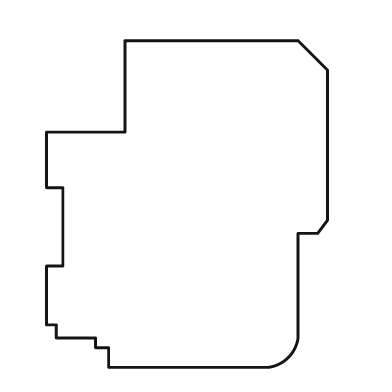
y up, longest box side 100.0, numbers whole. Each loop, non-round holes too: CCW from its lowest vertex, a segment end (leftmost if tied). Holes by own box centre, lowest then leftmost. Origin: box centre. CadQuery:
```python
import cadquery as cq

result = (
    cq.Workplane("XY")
    .moveTo(-24.0, -50.0)
    .lineTo(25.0, -50.0)
    .threePointArc((31.0, -47.0), (34.0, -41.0))
    .lineTo(34.0, -9.0)
    .lineTo(40.0, -9.0)
    .lineTo(43.0, -5.0)
    .lineTo(43.0, 41.0)
    .lineTo(34.0, 50.0)
    .lineTo(-19.0, 50.0)
    .lineTo(-19.0, 22.0)
    .lineTo(-43.0, 22.0)
    .lineTo(-43.0, 5.0)
    .lineTo(-38.0, 5.0)
    .lineTo(-38.0, -19.0)
    .lineTo(-43.0, -19.0)
    .lineTo(-43.0, -37.0)
    .lineTo(-40.0, -37.0)
    .lineTo(-40.0, -41.0)
    .lineTo(-28.0, -41.0)
    .lineTo(-28.0, -44.0)
    .lineTo(-24.0, -44.0)
    .close()
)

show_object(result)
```